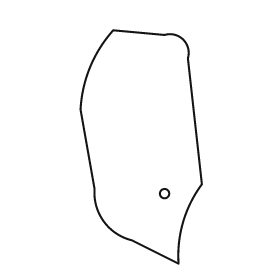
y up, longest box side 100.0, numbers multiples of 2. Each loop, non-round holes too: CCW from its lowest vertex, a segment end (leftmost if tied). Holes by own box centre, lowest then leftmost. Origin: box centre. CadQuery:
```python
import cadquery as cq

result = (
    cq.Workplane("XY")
    .moveTo(16.0, -50.0)
    .threePointArc((18.0, -32.0), (26.0, -16.0))
    .lineTo(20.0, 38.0)
    .threePointArc((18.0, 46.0), (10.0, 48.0))
    .lineTo(-12.0, 50.0)
    .threePointArc((-22.0, 34.0), (-26.0, 16.0))
    .lineTo(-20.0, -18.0)
    .threePointArc((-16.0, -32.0), (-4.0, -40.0))
    .close()
    .moveTo(10.0, -20.0)
    .circle(2.0)
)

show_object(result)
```